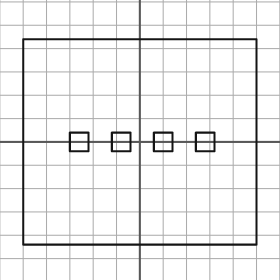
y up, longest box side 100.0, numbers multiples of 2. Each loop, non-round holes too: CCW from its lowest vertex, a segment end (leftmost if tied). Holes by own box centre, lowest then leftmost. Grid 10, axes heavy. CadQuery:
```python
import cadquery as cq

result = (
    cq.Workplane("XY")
    .moveTo(-50.0, -44.0)
    .lineTo(50.0, -44.0)
    .lineTo(50.0, 44.0)
    .lineTo(-50.0, 44.0)
    .close()
    .moveTo(-30.0, -4.0)
    .lineTo(-22.0, -4.0)
    .lineTo(-22.0, 4.0)
    .lineTo(-30.0, 4.0)
    .close()
    .moveTo(-12.0, -4.0)
    .lineTo(-4.0, -4.0)
    .lineTo(-4.0, 4.0)
    .lineTo(-12.0, 4.0)
    .close()
    .moveTo(6.0, -4.0)
    .lineTo(14.0, -4.0)
    .lineTo(14.0, 4.0)
    .lineTo(6.0, 4.0)
    .close()
    .moveTo(24.0, -4.0)
    .lineTo(32.0, -4.0)
    .lineTo(32.0, 4.0)
    .lineTo(24.0, 4.0)
    .close()
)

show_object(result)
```